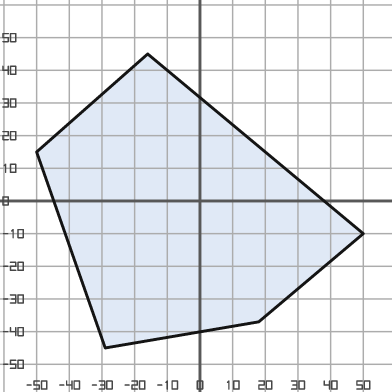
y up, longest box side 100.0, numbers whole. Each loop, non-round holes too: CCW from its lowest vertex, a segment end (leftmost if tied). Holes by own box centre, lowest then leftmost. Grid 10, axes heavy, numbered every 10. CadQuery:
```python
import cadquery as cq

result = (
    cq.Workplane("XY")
    .moveTo(-29.0, -45.0)
    .lineTo(18.0, -37.0)
    .lineTo(50.0, -10.0)
    .lineTo(-16.0, 45.0)
    .lineTo(-50.0, 15.0)
    .close()
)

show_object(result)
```